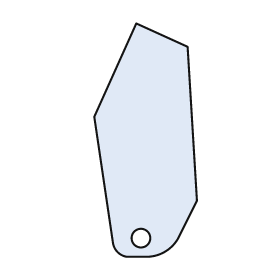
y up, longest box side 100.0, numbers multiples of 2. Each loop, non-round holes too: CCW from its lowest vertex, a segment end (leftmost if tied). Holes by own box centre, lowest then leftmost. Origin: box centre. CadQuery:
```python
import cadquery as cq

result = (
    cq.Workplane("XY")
    .moveTo(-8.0, -50.0)
    .lineTo(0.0, -50.0)
    .threePointArc((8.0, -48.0), (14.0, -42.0))
    .lineTo(22.0, -26.0)
    .lineTo(18.0, 40.0)
    .lineTo(-4.0, 50.0)
    .lineTo(-22.0, 10.0)
    .lineTo(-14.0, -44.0)
    .threePointArc((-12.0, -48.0), (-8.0, -50.0))
    .close()
    .moveTo(-2.0, -42.0)
    .circle(4.0)
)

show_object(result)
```